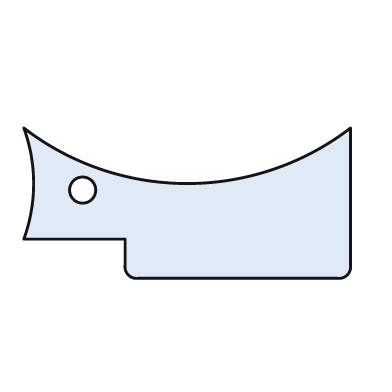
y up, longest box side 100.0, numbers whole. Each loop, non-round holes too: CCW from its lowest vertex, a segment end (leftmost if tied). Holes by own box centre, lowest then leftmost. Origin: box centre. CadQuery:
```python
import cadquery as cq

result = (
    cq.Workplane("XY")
    .moveTo(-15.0, -23.0)
    .lineTo(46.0, -23.0)
    .threePointArc((49.0, -22.0), (50.0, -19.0))
    .lineTo(50.0, 23.0)
    .threePointArc((0.0, 6.0), (-50.0, 23.0))
    .threePointArc((-47.0, 6.0), (-50.0, -11.0))
    .lineTo(-19.0, -11.0)
    .lineTo(-19.0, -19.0)
    .threePointArc((-18.0, -22.0), (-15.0, -23.0))
    .close()
    .moveTo(-32.0, 4.0)
    .circle(4.0)
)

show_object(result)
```